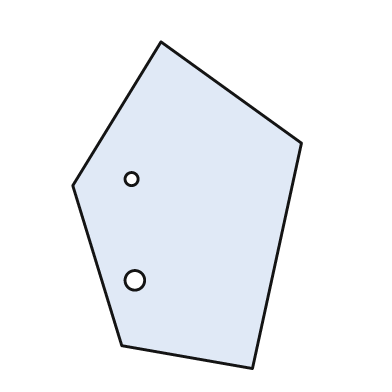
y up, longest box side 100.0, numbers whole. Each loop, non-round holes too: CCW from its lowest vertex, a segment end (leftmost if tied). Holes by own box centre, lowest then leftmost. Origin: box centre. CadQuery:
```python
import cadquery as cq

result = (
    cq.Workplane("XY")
    .moveTo(20.0, -50.0)
    .lineTo(35.0, 19.0)
    .lineTo(-8.0, 50.0)
    .lineTo(-35.0, 6.0)
    .lineTo(-20.0, -43.0)
    .close()
    .moveTo(-16.0, -23.0)
    .circle(3.0)
    .moveTo(-17.0, 8.0)
    .circle(2.0)
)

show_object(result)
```